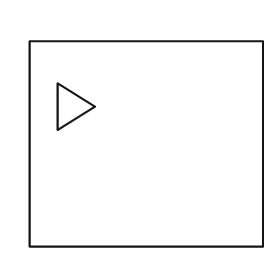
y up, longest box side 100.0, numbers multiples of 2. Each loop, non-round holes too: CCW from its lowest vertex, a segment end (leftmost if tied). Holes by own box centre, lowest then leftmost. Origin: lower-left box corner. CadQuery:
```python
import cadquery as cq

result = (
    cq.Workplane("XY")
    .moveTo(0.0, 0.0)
    .lineTo(100.0, 0.0)
    .lineTo(100.0, 88.0)
    .lineTo(0.0, 88.0)
    .close()
    .moveTo(12.0, 50.0)
    .lineTo(28.0, 60.0)
    .lineTo(12.0, 70.0)
    .close()
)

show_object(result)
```